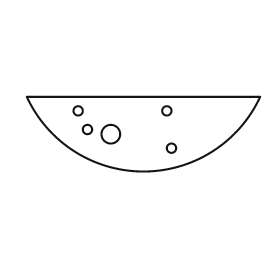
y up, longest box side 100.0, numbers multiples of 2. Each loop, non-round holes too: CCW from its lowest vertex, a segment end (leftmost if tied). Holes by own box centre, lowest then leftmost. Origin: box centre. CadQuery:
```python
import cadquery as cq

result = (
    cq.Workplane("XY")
    .moveTo(-50.0, 16.0)
    .threePointArc((0.0, -16.0), (50.0, 16.0))
    .close()
    .moveTo(12.0, -6.0)
    .circle(2.0)
    .moveTo(-14.0, 0.0)
    .circle(4.0)
    .moveTo(-24.0, 2.0)
    .circle(2.0)
    .moveTo(-28.0, 10.0)
    .circle(2.0)
    .moveTo(10.0, 10.0)
    .circle(2.0)
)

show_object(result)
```